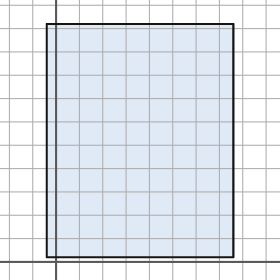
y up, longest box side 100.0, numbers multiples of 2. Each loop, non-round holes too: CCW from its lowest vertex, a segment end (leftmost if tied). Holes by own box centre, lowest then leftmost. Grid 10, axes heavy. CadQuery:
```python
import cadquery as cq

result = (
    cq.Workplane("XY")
    .moveTo(-4.0, 2.0)
    .lineTo(76.0, 2.0)
    .lineTo(76.0, 102.0)
    .lineTo(-4.0, 102.0)
    .close()
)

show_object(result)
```